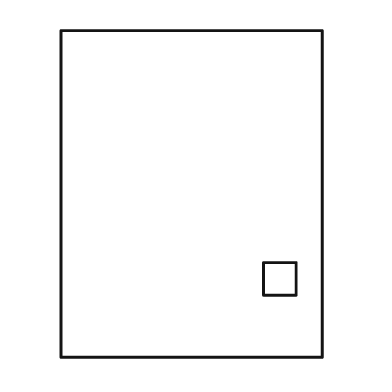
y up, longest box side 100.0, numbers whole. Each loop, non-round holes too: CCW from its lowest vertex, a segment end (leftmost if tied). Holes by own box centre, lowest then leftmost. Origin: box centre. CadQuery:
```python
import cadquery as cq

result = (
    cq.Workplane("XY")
    .moveTo(-40.0, -50.0)
    .lineTo(40.0, -50.0)
    .lineTo(40.0, 50.0)
    .lineTo(-40.0, 50.0)
    .close()
    .moveTo(22.0, -31.0)
    .lineTo(32.0, -31.0)
    .lineTo(32.0, -21.0)
    .lineTo(22.0, -21.0)
    .close()
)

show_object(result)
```